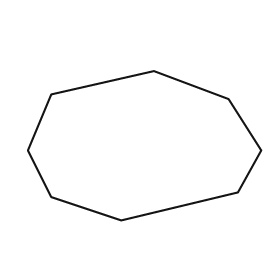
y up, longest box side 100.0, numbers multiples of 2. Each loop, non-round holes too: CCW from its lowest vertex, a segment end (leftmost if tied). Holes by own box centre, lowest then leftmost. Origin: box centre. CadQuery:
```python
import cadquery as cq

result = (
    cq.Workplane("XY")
    .moveTo(-10.0, -32.0)
    .lineTo(40.0, -20.0)
    .lineTo(50.0, -2.0)
    .lineTo(36.0, 20.0)
    .lineTo(4.0, 32.0)
    .lineTo(-40.0, 22.0)
    .lineTo(-50.0, -2.0)
    .lineTo(-40.0, -22.0)
    .close()
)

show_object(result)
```